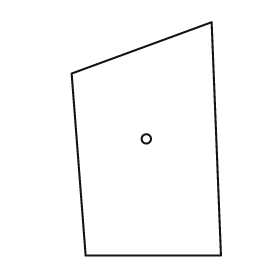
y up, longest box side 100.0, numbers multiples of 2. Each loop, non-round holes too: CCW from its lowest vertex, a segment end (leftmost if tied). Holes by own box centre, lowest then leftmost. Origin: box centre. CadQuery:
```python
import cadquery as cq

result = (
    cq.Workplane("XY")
    .moveTo(-26.0, -50.0)
    .lineTo(32.0, -50.0)
    .lineTo(28.0, 50.0)
    .lineTo(-32.0, 28.0)
    .close()
    .moveTo(0.0, 0.0)
    .circle(2.0)
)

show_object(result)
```